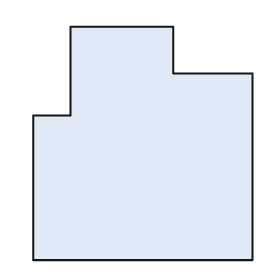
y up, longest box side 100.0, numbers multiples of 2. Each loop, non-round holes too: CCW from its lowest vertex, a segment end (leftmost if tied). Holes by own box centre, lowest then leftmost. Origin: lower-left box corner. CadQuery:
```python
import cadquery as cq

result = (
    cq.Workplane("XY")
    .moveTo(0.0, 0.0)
    .lineTo(94.0, 0.0)
    .lineTo(94.0, 80.0)
    .lineTo(60.0, 80.0)
    .lineTo(60.0, 100.0)
    .lineTo(16.0, 100.0)
    .lineTo(16.0, 62.0)
    .lineTo(0.0, 62.0)
    .close()
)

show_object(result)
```